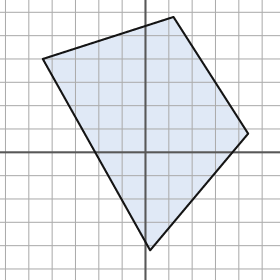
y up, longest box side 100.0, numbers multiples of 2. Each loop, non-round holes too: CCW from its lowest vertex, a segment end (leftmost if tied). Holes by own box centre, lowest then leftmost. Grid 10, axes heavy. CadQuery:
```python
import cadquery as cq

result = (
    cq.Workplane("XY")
    .moveTo(2.0, -42.0)
    .lineTo(44.0, 8.0)
    .lineTo(12.0, 58.0)
    .lineTo(-44.0, 40.0)
    .close()
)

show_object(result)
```